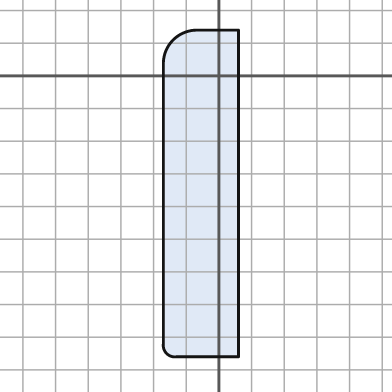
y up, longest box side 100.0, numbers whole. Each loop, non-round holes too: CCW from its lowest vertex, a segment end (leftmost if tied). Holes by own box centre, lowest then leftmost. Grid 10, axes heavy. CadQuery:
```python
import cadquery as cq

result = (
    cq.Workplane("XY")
    .moveTo(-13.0, -86.0)
    .lineTo(6.0, -86.0)
    .lineTo(6.0, 14.0)
    .lineTo(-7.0, 14.0)
    .threePointArc((-14.0, 11.0), (-17.0, 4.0))
    .lineTo(-17.0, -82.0)
    .threePointArc((-16.0, -85.0), (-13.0, -86.0))
    .close()
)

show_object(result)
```